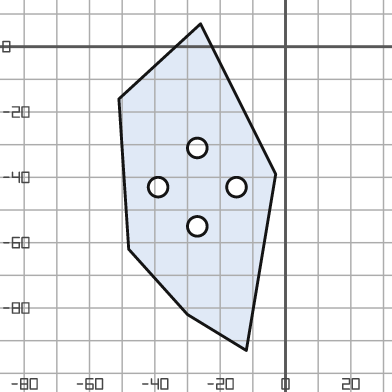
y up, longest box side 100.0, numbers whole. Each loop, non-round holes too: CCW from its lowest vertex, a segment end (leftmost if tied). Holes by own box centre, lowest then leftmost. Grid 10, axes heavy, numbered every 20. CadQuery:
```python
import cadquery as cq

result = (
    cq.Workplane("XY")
    .moveTo(-12.0, -93.0)
    .lineTo(-3.0, -39.0)
    .lineTo(-26.0, 7.0)
    .lineTo(-51.0, -16.0)
    .lineTo(-48.0, -62.0)
    .lineTo(-30.0, -82.0)
    .close()
    .moveTo(-27.0, -55.0)
    .circle(3.0)
    .moveTo(-39.0, -43.0)
    .circle(3.0)
    .moveTo(-15.0, -43.0)
    .circle(3.0)
    .moveTo(-27.0, -31.0)
    .circle(3.0)
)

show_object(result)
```